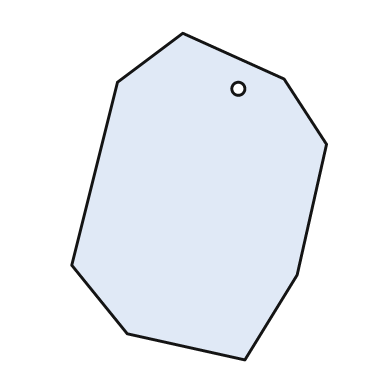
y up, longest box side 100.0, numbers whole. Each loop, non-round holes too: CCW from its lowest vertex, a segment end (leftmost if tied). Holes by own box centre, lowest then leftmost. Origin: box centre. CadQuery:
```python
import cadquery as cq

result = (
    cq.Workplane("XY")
    .moveTo(14.0, -50.0)
    .lineTo(30.0, -24.0)
    .lineTo(39.0, 16.0)
    .lineTo(26.0, 36.0)
    .lineTo(-5.0, 50.0)
    .lineTo(-25.0, 35.0)
    .lineTo(-39.0, -21.0)
    .lineTo(-22.0, -42.0)
    .close()
    .moveTo(12.0, 33.0)
    .circle(2.0)
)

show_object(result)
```